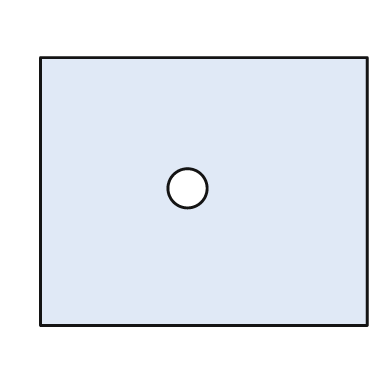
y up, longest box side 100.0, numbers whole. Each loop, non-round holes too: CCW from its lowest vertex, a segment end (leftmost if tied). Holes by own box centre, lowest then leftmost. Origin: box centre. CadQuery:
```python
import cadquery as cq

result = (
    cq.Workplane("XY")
    .moveTo(-50.0, -41.0)
    .lineTo(50.0, -41.0)
    .lineTo(50.0, 41.0)
    .lineTo(-50.0, 41.0)
    .close()
    .moveTo(-5.0, 1.0)
    .circle(6.0)
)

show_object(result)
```